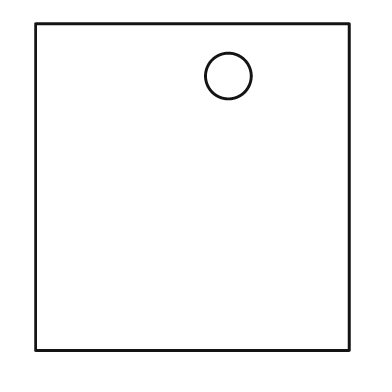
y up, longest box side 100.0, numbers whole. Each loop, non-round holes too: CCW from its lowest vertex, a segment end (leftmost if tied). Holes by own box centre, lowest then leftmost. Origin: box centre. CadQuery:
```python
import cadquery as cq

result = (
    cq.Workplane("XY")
    .moveTo(-48.0, -50.0)
    .lineTo(48.0, -50.0)
    .lineTo(48.0, 50.0)
    .lineTo(-48.0, 50.0)
    .close()
    .moveTo(11.0, 34.0)
    .circle(7.0)
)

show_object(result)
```